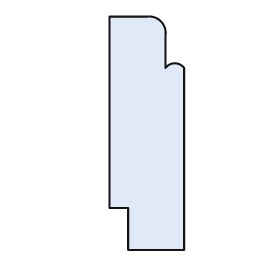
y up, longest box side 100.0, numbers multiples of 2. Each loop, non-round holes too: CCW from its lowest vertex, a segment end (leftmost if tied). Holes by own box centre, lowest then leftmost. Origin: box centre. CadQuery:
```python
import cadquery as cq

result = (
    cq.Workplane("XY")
    .moveTo(-8.0, -50.0)
    .lineTo(16.0, -50.0)
    .lineTo(16.0, 28.0)
    .threePointArc((12.0, 30.0), (8.0, 28.0))
    .lineTo(8.0, 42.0)
    .threePointArc((6.0, 48.0), (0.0, 50.0))
    .lineTo(-16.0, 50.0)
    .lineTo(-16.0, -32.0)
    .lineTo(-8.0, -32.0)
    .close()
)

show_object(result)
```